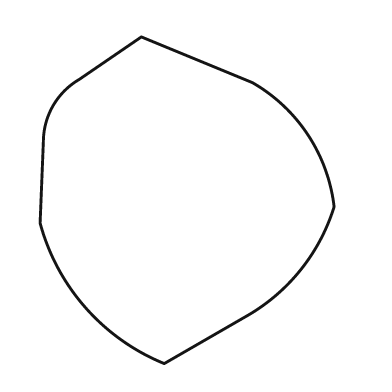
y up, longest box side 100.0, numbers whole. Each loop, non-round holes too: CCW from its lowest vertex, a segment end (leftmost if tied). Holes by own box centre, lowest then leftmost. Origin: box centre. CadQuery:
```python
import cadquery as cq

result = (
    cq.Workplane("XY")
    .moveTo(-7.0, -50.0)
    .lineTo(19.0, -35.0)
    .threePointArc((35.0, -21.0), (45.0, -2.0))
    .threePointArc((37.0, 20.0), (20.0, 36.0))
    .lineTo(-14.0, 50.0)
    .lineTo(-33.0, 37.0)
    .threePointArc((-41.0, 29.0), (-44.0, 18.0))
    .lineTo(-45.0, -7.0)
    .threePointArc((-31.0, -33.0), (-7.0, -50.0))
    .close()
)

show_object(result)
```